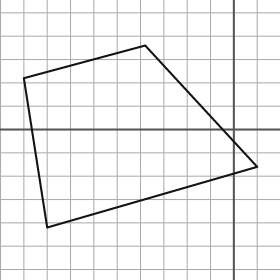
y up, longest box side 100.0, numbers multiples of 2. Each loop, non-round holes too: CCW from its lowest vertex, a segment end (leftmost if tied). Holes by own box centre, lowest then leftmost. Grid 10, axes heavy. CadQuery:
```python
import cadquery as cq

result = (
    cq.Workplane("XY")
    .moveTo(-80.0, -42.0)
    .lineTo(10.0, -16.0)
    .lineTo(-38.0, 36.0)
    .lineTo(-90.0, 22.0)
    .close()
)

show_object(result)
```